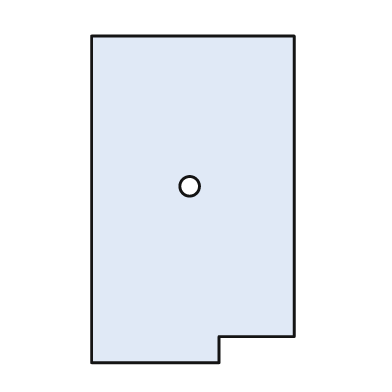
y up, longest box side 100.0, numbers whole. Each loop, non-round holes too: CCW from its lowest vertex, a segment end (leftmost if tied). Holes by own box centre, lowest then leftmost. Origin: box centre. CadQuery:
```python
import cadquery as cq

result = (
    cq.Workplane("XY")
    .moveTo(-31.0, -50.0)
    .lineTo(8.0, -50.0)
    .lineTo(8.0, -42.0)
    .lineTo(31.0, -42.0)
    .lineTo(31.0, 50.0)
    .lineTo(-31.0, 50.0)
    .close()
    .moveTo(-1.0, 4.0)
    .circle(3.0)
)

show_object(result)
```